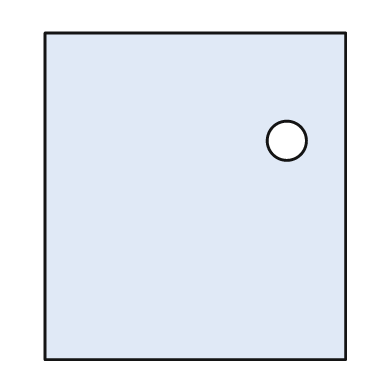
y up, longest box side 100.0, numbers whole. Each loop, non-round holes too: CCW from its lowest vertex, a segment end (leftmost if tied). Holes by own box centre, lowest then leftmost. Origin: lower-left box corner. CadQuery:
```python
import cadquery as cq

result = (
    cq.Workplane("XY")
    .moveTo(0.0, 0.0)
    .lineTo(92.0, 0.0)
    .lineTo(92.0, 100.0)
    .lineTo(0.0, 100.0)
    .close()
    .moveTo(74.0, 67.0)
    .circle(6.0)
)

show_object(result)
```